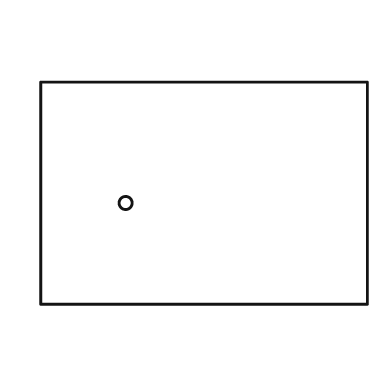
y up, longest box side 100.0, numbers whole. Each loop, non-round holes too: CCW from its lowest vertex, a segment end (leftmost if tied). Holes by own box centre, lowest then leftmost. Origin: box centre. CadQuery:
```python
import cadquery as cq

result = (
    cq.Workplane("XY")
    .moveTo(-50.0, -34.0)
    .lineTo(50.0, -34.0)
    .lineTo(50.0, 34.0)
    .lineTo(-50.0, 34.0)
    .close()
    .moveTo(-24.0, -3.0)
    .circle(2.0)
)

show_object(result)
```